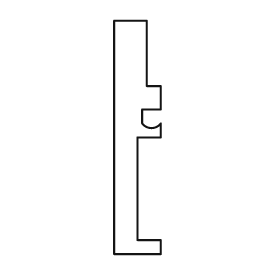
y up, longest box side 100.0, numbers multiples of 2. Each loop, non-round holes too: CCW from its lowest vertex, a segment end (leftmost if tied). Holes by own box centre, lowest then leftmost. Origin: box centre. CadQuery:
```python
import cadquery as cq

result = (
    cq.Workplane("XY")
    .moveTo(-10.0, -50.0)
    .lineTo(10.0, -50.0)
    .lineTo(10.0, -44.0)
    .lineTo(0.0, -44.0)
    .lineTo(0.0, 0.0)
    .lineTo(10.0, 0.0)
    .lineTo(10.0, 6.0)
    .threePointArc((6.0, 4.0), (2.0, 6.0))
    .lineTo(2.0, 12.0)
    .lineTo(10.0, 12.0)
    .lineTo(10.0, 22.0)
    .lineTo(4.0, 22.0)
    .lineTo(4.0, 50.0)
    .lineTo(-10.0, 50.0)
    .close()
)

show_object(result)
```